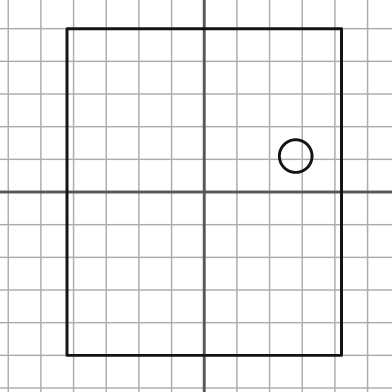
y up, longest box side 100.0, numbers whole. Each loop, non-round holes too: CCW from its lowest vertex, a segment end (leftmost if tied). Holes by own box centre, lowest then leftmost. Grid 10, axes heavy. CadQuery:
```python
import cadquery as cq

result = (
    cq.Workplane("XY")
    .moveTo(-42.0, -50.0)
    .lineTo(42.0, -50.0)
    .lineTo(42.0, 50.0)
    .lineTo(-42.0, 50.0)
    .close()
    .moveTo(28.0, 11.0)
    .circle(5.0)
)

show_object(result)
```